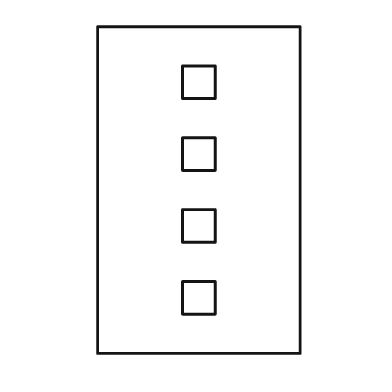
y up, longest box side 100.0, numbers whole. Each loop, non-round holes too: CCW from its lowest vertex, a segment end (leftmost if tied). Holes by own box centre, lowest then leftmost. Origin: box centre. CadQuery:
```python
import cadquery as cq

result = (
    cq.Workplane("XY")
    .moveTo(-31.0, -50.0)
    .lineTo(31.0, -50.0)
    .lineTo(31.0, 50.0)
    .lineTo(-31.0, 50.0)
    .close()
    .moveTo(-5.0, -38.0)
    .lineTo(5.0, -38.0)
    .lineTo(5.0, -28.0)
    .lineTo(-5.0, -28.0)
    .close()
    .moveTo(-5.0, -16.0)
    .lineTo(5.0, -16.0)
    .lineTo(5.0, -6.0)
    .lineTo(-5.0, -6.0)
    .close()
    .moveTo(-5.0, 6.0)
    .lineTo(5.0, 6.0)
    .lineTo(5.0, 16.0)
    .lineTo(-5.0, 16.0)
    .close()
    .moveTo(-5.0, 28.0)
    .lineTo(5.0, 28.0)
    .lineTo(5.0, 38.0)
    .lineTo(-5.0, 38.0)
    .close()
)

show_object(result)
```